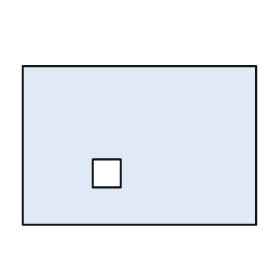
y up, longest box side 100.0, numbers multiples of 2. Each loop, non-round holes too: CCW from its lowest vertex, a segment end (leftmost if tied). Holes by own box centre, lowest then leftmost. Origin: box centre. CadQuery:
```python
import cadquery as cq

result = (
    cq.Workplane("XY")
    .moveTo(-50.0, -34.0)
    .lineTo(50.0, -34.0)
    .lineTo(50.0, 34.0)
    .lineTo(-50.0, 34.0)
    .close()
    .moveTo(-20.0, -18.0)
    .lineTo(-8.0, -18.0)
    .lineTo(-8.0, -6.0)
    .lineTo(-20.0, -6.0)
    .close()
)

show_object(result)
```